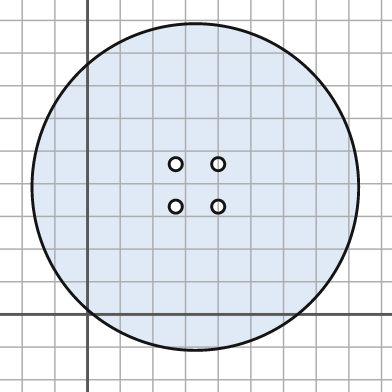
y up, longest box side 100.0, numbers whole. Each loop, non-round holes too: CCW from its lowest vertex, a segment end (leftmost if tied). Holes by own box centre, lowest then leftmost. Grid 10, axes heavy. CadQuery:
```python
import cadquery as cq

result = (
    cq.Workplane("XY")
    .moveTo(33.0, 39.0)
    .circle(50.0)
    .moveTo(27.0, 33.0)
    .circle(2.0)
    .moveTo(40.0, 33.0)
    .circle(2.0)
    .moveTo(27.0, 46.0)
    .circle(2.0)
    .moveTo(40.0, 46.0)
    .circle(2.0)
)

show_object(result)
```